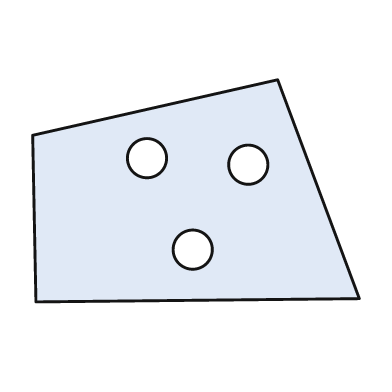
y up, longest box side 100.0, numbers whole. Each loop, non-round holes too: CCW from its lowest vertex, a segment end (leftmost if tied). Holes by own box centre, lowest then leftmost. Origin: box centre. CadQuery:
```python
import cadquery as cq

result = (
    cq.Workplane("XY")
    .moveTo(-49.0, -34.0)
    .lineTo(50.0, -33.0)
    .lineTo(25.0, 34.0)
    .lineTo(-50.0, 17.0)
    .close()
    .moveTo(-1.0, -18.0)
    .circle(6.0)
    .moveTo(16.0, 8.0)
    .circle(6.0)
    .moveTo(-15.0, 10.0)
    .circle(6.0)
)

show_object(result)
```